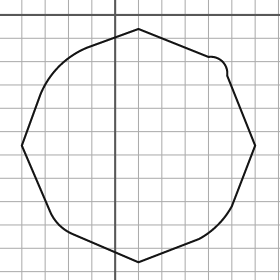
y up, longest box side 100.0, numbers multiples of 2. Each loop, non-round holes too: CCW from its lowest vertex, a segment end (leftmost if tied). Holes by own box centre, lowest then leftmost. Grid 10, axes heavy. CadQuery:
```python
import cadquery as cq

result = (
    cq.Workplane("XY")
    .moveTo(10.0, -106.0)
    .lineTo(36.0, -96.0)
    .threePointArc((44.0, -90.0), (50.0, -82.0))
    .lineTo(60.0, -56.0)
    .lineTo(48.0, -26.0)
    .threePointArc((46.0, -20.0), (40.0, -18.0))
    .lineTo(10.0, -6.0)
    .lineTo(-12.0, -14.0)
    .threePointArc((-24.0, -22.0), (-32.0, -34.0))
    .lineTo(-40.0, -56.0)
    .lineTo(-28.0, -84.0)
    .threePointArc((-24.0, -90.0), (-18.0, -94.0))
    .close()
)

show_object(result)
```